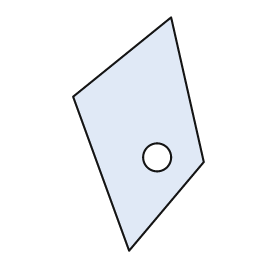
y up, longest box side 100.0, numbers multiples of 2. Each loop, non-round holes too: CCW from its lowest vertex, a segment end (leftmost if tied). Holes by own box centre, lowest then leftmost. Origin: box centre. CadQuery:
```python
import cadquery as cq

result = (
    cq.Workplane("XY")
    .moveTo(-4.0, -50.0)
    .lineTo(28.0, -12.0)
    .lineTo(14.0, 50.0)
    .lineTo(-28.0, 16.0)
    .close()
    .moveTo(8.0, -10.0)
    .circle(6.0)
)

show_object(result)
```